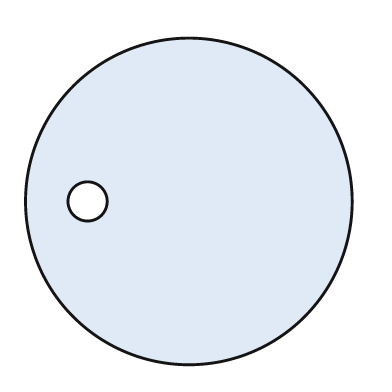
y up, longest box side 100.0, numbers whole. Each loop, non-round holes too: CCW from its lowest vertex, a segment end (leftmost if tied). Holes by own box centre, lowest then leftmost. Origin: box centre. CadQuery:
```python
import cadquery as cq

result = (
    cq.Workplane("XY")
    .moveTo(0.0, 0.0)
    .circle(50.0)
    .moveTo(-31.0, 0.0)
    .circle(6.0)
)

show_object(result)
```